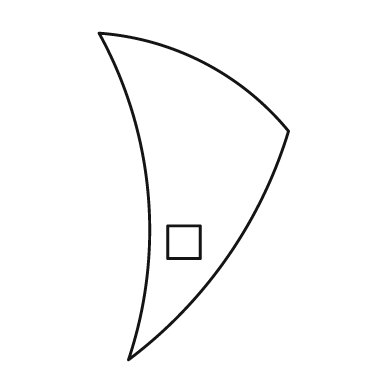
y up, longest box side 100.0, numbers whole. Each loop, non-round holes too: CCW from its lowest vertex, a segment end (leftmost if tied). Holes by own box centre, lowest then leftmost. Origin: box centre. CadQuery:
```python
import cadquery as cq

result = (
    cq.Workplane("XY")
    .moveTo(-20.0, -50.0)
    .threePointArc((10.0, -19.0), (29.0, 20.0))
    .threePointArc((3.0, 41.0), (-29.0, 50.0))
    .threePointArc((-14.0, 1.0), (-20.0, -50.0))
    .close()
    .moveTo(-8.0, -19.0)
    .lineTo(2.0, -19.0)
    .lineTo(2.0, -9.0)
    .lineTo(-8.0, -9.0)
    .close()
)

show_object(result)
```